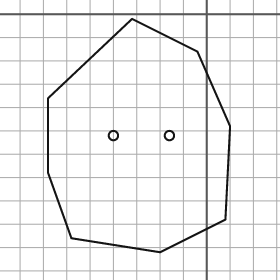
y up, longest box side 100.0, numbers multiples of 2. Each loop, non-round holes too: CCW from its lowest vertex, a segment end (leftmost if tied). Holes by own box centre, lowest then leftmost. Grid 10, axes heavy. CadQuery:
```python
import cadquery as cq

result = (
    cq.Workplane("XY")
    .moveTo(-20.0, -102.0)
    .lineTo(8.0, -88.0)
    .lineTo(10.0, -48.0)
    .lineTo(-4.0, -16.0)
    .lineTo(-32.0, -2.0)
    .lineTo(-68.0, -36.0)
    .lineTo(-68.0, -68.0)
    .lineTo(-58.0, -96.0)
    .close()
    .moveTo(-40.0, -52.0)
    .circle(2.0)
    .moveTo(-16.0, -52.0)
    .circle(2.0)
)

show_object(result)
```